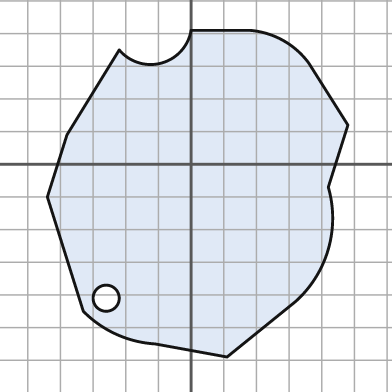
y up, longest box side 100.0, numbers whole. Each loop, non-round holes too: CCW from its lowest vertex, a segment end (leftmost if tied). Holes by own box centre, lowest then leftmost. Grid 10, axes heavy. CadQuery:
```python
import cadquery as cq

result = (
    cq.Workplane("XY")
    .moveTo(11.0, -59.0)
    .lineTo(32.0, -42.0)
    .threePointArc((42.0, -26.0), (42.0, -7.0))
    .lineTo(48.0, 12.0)
    .lineTo(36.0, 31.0)
    .threePointArc((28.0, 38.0), (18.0, 41.0))
    .lineTo(0.0, 41.0)
    .threePointArc((-9.0, 31.0), (-22.0, 35.0))
    .lineTo(-38.0, 9.0)
    .lineTo(-44.0, -10.0)
    .lineTo(-33.0, -45.0)
    .threePointArc((-23.0, -52.0), (-11.0, -55.0))
    .close()
    .moveTo(-26.0, -41.0)
    .circle(4.0)
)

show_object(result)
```